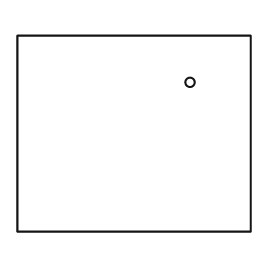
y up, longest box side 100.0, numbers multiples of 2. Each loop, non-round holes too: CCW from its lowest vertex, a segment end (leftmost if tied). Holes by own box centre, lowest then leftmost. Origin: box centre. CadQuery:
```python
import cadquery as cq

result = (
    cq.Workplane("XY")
    .moveTo(-50.0, -42.0)
    .lineTo(50.0, -42.0)
    .lineTo(50.0, 42.0)
    .lineTo(-50.0, 42.0)
    .close()
    .moveTo(24.0, 22.0)
    .circle(2.0)
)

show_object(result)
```